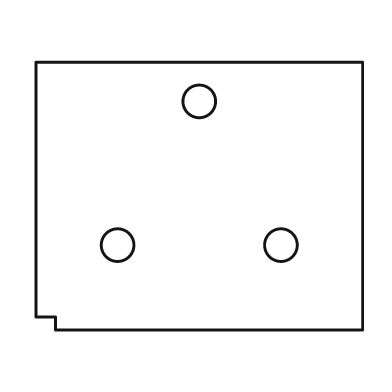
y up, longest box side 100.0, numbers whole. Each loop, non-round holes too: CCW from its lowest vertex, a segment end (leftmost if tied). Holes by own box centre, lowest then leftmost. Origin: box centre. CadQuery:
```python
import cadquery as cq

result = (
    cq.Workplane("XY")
    .moveTo(-44.0, -41.0)
    .lineTo(50.0, -41.0)
    .lineTo(50.0, 41.0)
    .lineTo(-50.0, 41.0)
    .lineTo(-50.0, -37.0)
    .lineTo(-44.0, -37.0)
    .close()
    .moveTo(-25.0, -15.0)
    .circle(5.0)
    .moveTo(25.0, -15.0)
    .circle(5.0)
    .moveTo(0.0, 29.0)
    .circle(5.0)
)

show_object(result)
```